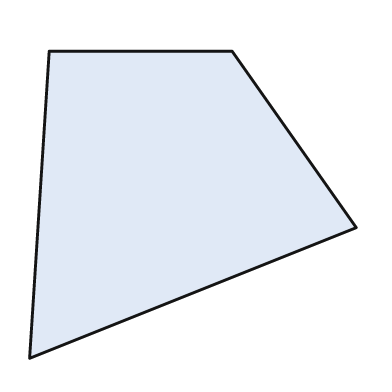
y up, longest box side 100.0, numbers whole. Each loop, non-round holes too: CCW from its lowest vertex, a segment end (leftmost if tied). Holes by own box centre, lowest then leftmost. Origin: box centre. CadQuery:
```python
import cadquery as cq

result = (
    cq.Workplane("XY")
    .moveTo(-50.0, -47.0)
    .lineTo(50.0, -7.0)
    .lineTo(12.0, 47.0)
    .lineTo(-44.0, 47.0)
    .close()
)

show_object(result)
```